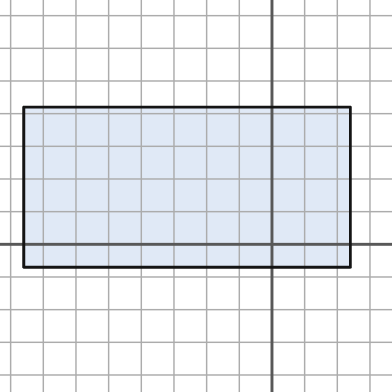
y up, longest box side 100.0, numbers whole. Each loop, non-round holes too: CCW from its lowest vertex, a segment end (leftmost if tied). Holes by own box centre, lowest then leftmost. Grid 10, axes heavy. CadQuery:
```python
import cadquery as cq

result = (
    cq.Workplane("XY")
    .moveTo(-76.0, -7.0)
    .lineTo(24.0, -7.0)
    .lineTo(24.0, 42.0)
    .lineTo(-76.0, 42.0)
    .close()
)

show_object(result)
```